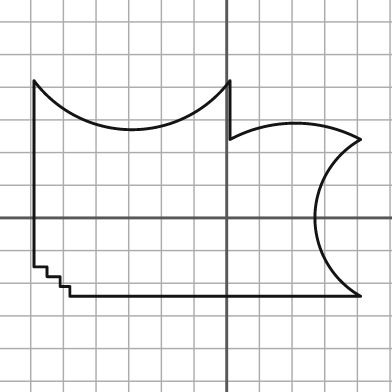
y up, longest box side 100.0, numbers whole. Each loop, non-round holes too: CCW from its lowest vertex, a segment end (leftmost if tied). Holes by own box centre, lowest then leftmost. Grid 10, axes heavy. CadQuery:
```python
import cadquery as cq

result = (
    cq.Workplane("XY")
    .moveTo(-48.0, -24.0)
    .lineTo(41.0, -24.0)
    .threePointArc((27.0, 0.0), (41.0, 24.0))
    .threePointArc((21.0, 29.0), (1.0, 24.0))
    .lineTo(1.0, 42.0)
    .threePointArc((-29.0, 27.0), (-59.0, 42.0))
    .lineTo(-59.0, -15.0)
    .lineTo(-55.0, -15.0)
    .lineTo(-55.0, -18.0)
    .lineTo(-51.0, -18.0)
    .lineTo(-51.0, -21.0)
    .lineTo(-48.0, -21.0)
    .close()
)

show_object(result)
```